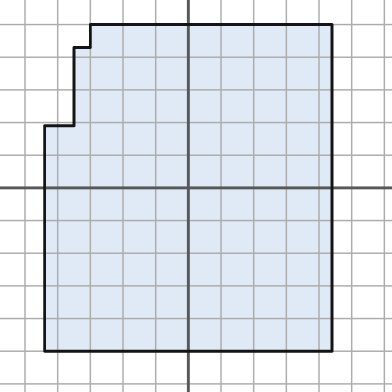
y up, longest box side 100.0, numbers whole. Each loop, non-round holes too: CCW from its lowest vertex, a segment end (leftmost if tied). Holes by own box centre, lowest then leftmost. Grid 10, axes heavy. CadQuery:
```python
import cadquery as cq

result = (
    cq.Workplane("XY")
    .moveTo(-44.0, -50.0)
    .lineTo(44.0, -50.0)
    .lineTo(44.0, 50.0)
    .lineTo(-30.0, 50.0)
    .lineTo(-30.0, 43.0)
    .lineTo(-35.0, 43.0)
    .lineTo(-35.0, 19.0)
    .lineTo(-44.0, 19.0)
    .close()
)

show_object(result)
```